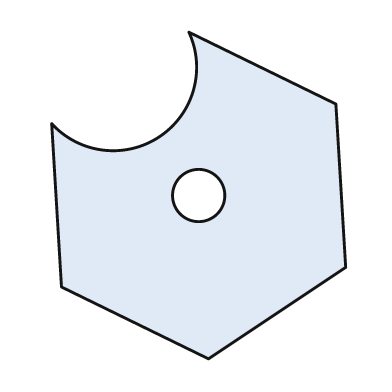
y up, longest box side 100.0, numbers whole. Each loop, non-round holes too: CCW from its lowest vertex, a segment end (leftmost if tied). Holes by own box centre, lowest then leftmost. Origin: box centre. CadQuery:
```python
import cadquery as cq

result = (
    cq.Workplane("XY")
    .moveTo(3.0, -50.0)
    .lineTo(45.0, -22.0)
    .lineTo(42.0, 28.0)
    .lineTo(-3.0, 50.0)
    .threePointArc((-12.0, 18.0), (-45.0, 22.0))
    .lineTo(-42.0, -28.0)
    .close()
    .moveTo(0.0, 0.0)
    .circle(8.0)
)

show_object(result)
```